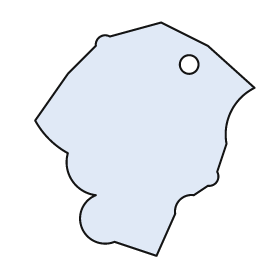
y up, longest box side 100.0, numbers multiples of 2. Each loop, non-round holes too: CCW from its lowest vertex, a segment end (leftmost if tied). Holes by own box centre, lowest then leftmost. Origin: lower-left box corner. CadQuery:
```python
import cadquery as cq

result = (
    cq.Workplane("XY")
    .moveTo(52.0, 0.0)
    .lineTo(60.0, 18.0)
    .threePointArc((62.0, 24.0), (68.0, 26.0))
    .lineTo(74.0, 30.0)
    .threePointArc((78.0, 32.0), (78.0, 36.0))
    .lineTo(82.0, 48.0)
    .threePointArc((84.0, 62.0), (94.0, 72.0))
    .lineTo(74.0, 90.0)
    .lineTo(54.0, 100.0)
    .lineTo(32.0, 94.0)
    .threePointArc((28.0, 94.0), (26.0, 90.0))
    .lineTo(14.0, 78.0)
    .lineTo(0.0, 58.0)
    .threePointArc((6.0, 50.0), (14.0, 44.0))
    .threePointArc((16.0, 32.0), (26.0, 26.0))
    .threePointArc((20.0, 12.0), (34.0, 6.0))
    .close()
    .moveTo(66.0, 82.0)
    .circle(4.0)
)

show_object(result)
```